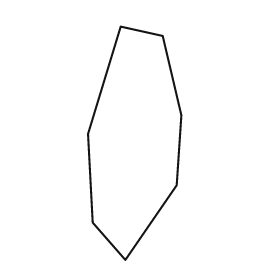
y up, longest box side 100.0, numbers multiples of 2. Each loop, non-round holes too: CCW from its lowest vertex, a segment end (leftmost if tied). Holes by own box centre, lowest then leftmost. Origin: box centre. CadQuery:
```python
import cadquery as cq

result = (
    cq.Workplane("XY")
    .moveTo(-4.0, -50.0)
    .lineTo(18.0, -18.0)
    .lineTo(20.0, 12.0)
    .lineTo(12.0, 46.0)
    .lineTo(-6.0, 50.0)
    .lineTo(-20.0, 4.0)
    .lineTo(-18.0, -34.0)
    .close()
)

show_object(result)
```